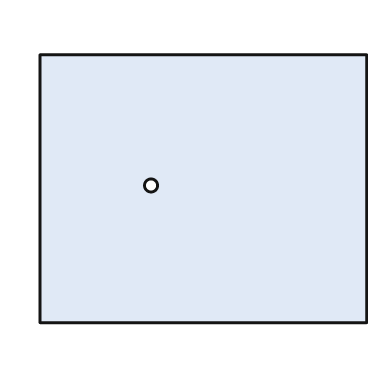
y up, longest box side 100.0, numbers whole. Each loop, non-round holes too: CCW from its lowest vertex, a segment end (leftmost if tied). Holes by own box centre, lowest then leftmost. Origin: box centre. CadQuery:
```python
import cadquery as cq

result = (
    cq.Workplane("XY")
    .moveTo(-50.0, -41.0)
    .lineTo(50.0, -41.0)
    .lineTo(50.0, 41.0)
    .lineTo(-50.0, 41.0)
    .close()
    .moveTo(-16.0, 1.0)
    .circle(2.0)
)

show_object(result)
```